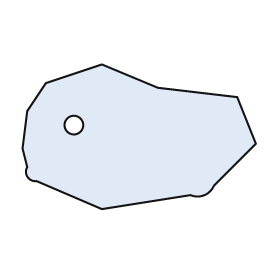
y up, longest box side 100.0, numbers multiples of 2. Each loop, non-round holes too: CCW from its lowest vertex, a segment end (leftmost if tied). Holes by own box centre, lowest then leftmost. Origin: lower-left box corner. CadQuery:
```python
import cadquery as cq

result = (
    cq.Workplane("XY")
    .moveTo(34.0, 0.0)
    .lineTo(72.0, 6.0)
    .threePointArc((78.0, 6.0), (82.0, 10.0))
    .lineTo(100.0, 28.0)
    .lineTo(92.0, 48.0)
    .lineTo(58.0, 52.0)
    .lineTo(34.0, 62.0)
    .lineTo(10.0, 54.0)
    .lineTo(2.0, 42.0)
    .lineTo(0.0, 26.0)
    .lineTo(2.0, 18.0)
    .threePointArc((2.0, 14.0), (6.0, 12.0))
    .close()
    .moveTo(22.0, 36.0)
    .circle(4.0)
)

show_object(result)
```